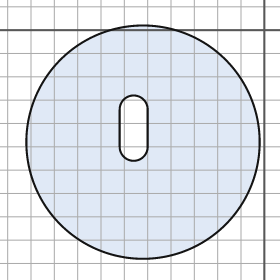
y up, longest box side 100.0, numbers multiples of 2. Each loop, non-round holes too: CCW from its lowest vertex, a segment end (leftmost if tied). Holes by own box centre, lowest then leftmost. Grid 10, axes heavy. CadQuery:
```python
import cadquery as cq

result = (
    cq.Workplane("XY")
    .moveTo(-52.0, -48.0)
    .circle(50.0)
    .moveTo(-62.0, -50.0)
    .threePointArc((-56.0, -56.0), (-50.0, -50.0))
    .lineTo(-50.0, -34.0)
    .threePointArc((-56.0, -28.0), (-62.0, -34.0))
    .close()
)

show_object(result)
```